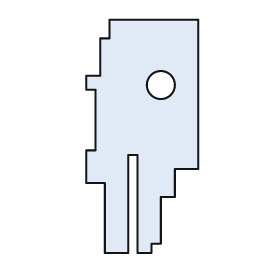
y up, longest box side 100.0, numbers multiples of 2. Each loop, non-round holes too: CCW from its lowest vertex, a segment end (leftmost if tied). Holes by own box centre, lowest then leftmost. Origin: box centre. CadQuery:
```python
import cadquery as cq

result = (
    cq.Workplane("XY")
    .moveTo(-16.0, -50.0)
    .lineTo(-6.0, -50.0)
    .lineTo(-6.0, -8.0)
    .lineTo(-2.0, -8.0)
    .lineTo(-2.0, -50.0)
    .lineTo(4.0, -50.0)
    .lineTo(4.0, -46.0)
    .lineTo(8.0, -46.0)
    .lineTo(8.0, -26.0)
    .lineTo(14.0, -26.0)
    .lineTo(14.0, -14.0)
    .lineTo(24.0, -14.0)
    .lineTo(24.0, 50.0)
    .lineTo(-14.0, 50.0)
    .lineTo(-14.0, 42.0)
    .lineTo(-18.0, 42.0)
    .lineTo(-18.0, 26.0)
    .lineTo(-24.0, 26.0)
    .lineTo(-24.0, 20.0)
    .lineTo(-20.0, 20.0)
    .lineTo(-20.0, -6.0)
    .lineTo(-24.0, -6.0)
    .lineTo(-24.0, -20.0)
    .lineTo(-16.0, -20.0)
    .close()
    .moveTo(8.0, 22.0)
    .circle(6.0)
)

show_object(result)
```